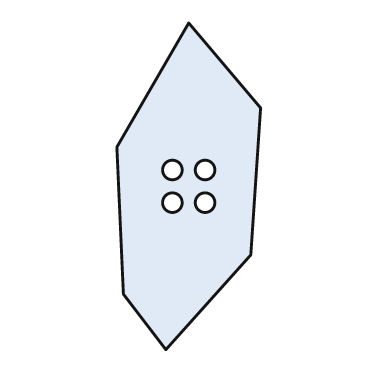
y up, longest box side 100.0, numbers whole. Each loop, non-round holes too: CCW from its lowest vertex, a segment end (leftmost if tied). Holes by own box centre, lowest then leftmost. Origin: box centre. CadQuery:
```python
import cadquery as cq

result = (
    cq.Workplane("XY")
    .moveTo(-7.0, -50.0)
    .lineTo(19.0, -21.0)
    .lineTo(22.0, 24.0)
    .lineTo(0.0, 50.0)
    .lineTo(-22.0, 12.0)
    .lineTo(-20.0, -33.0)
    .close()
    .moveTo(-5.0, -5.0)
    .circle(3.0)
    .moveTo(5.0, -5.0)
    .circle(3.0)
    .moveTo(-5.0, 5.0)
    .circle(3.0)
    .moveTo(5.0, 5.0)
    .circle(3.0)
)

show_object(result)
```